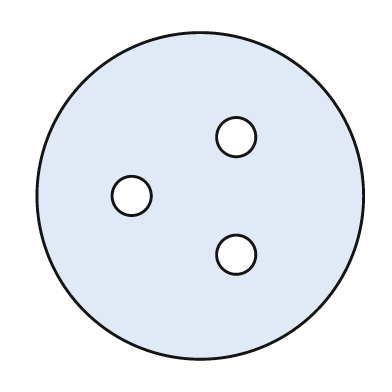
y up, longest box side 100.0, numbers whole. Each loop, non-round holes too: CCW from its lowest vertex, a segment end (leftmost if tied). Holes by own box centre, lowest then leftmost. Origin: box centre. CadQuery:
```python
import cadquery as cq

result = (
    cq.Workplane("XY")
    .moveTo(0.0, 0.0)
    .circle(50.0)
    .moveTo(11.0, -18.0)
    .circle(6.0)
    .moveTo(-21.0, 0.0)
    .circle(6.0)
    .moveTo(11.0, 18.0)
    .circle(6.0)
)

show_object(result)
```